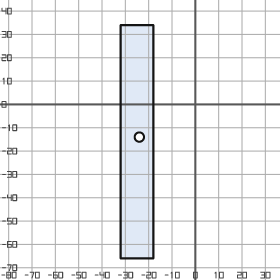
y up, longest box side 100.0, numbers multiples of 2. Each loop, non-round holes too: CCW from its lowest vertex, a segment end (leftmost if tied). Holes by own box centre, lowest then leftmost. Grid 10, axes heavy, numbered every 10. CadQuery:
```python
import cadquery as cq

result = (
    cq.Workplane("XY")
    .moveTo(-32.0, -66.0)
    .lineTo(-18.0, -66.0)
    .lineTo(-18.0, 34.0)
    .lineTo(-32.0, 34.0)
    .close()
    .moveTo(-24.0, -14.0)
    .circle(2.0)
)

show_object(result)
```